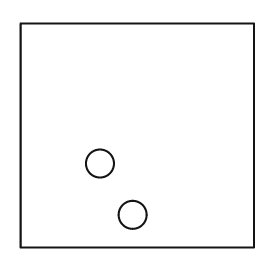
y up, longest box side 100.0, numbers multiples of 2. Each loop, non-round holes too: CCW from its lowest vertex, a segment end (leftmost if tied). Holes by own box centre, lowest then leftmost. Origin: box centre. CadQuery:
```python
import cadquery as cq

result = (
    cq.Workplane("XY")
    .moveTo(-50.0, -48.0)
    .lineTo(50.0, -48.0)
    .lineTo(50.0, 48.0)
    .lineTo(-50.0, 48.0)
    .close()
    .moveTo(-2.0, -34.0)
    .circle(6.0)
    .moveTo(-16.0, -12.0)
    .circle(6.0)
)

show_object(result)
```